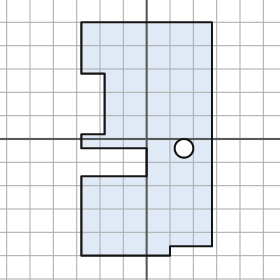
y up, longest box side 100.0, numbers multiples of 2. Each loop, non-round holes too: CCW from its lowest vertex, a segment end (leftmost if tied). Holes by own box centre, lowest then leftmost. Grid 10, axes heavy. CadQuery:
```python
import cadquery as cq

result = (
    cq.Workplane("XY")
    .moveTo(-28.0, -50.0)
    .lineTo(10.0, -50.0)
    .lineTo(10.0, -46.0)
    .lineTo(28.0, -46.0)
    .lineTo(28.0, 50.0)
    .lineTo(-28.0, 50.0)
    .lineTo(-28.0, 28.0)
    .lineTo(-18.0, 28.0)
    .lineTo(-18.0, 2.0)
    .lineTo(-28.0, 2.0)
    .lineTo(-28.0, -4.0)
    .lineTo(0.0, -4.0)
    .lineTo(0.0, -16.0)
    .lineTo(-28.0, -16.0)
    .close()
    .moveTo(16.0, -4.0)
    .circle(4.0)
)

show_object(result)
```